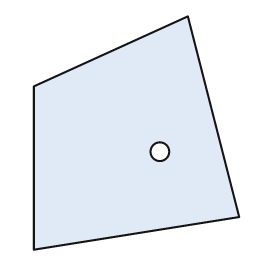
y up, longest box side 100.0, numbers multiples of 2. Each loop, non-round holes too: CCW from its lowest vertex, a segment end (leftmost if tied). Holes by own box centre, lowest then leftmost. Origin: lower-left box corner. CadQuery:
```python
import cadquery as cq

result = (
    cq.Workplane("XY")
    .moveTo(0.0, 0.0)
    .lineTo(88.0, 14.0)
    .lineTo(66.0, 100.0)
    .lineTo(0.0, 70.0)
    .close()
    .moveTo(54.0, 42.0)
    .circle(4.0)
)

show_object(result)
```